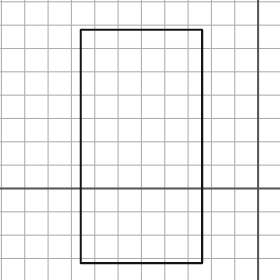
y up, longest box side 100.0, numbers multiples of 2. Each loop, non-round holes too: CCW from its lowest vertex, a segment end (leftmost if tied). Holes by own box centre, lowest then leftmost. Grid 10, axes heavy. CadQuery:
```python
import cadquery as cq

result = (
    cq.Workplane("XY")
    .moveTo(-76.0, -32.0)
    .lineTo(-24.0, -32.0)
    .lineTo(-24.0, 68.0)
    .lineTo(-76.0, 68.0)
    .close()
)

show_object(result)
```